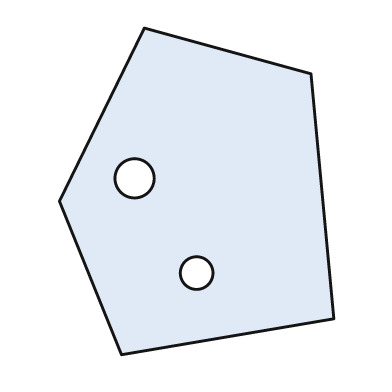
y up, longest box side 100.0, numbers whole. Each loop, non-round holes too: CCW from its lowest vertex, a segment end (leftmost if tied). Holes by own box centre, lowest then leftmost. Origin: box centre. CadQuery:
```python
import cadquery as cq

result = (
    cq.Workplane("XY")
    .moveTo(-23.0, -50.0)
    .lineTo(42.0, -39.0)
    .lineTo(35.0, 36.0)
    .lineTo(-16.0, 50.0)
    .lineTo(-42.0, -3.0)
    .close()
    .moveTo(0.0, -25.0)
    .circle(5.0)
    .moveTo(-19.0, 4.0)
    .circle(6.0)
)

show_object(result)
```